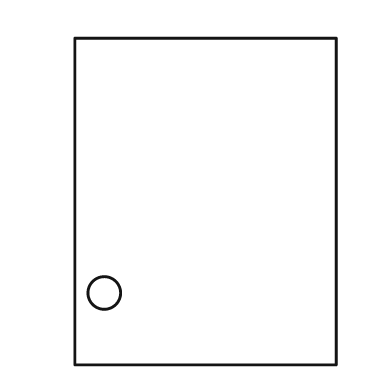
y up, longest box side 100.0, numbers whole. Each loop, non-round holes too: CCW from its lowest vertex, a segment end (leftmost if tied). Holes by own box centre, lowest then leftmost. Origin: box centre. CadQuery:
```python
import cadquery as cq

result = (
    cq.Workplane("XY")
    .moveTo(-40.0, -50.0)
    .lineTo(40.0, -50.0)
    .lineTo(40.0, 50.0)
    .lineTo(-40.0, 50.0)
    .close()
    .moveTo(-31.0, -28.0)
    .circle(5.0)
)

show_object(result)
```